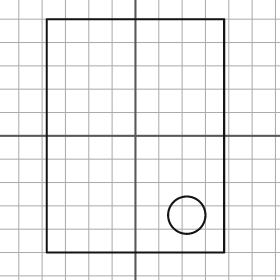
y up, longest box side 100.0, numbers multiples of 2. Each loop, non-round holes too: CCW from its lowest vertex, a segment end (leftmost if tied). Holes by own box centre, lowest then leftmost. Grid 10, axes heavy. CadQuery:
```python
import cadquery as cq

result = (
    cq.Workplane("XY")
    .moveTo(-38.0, -50.0)
    .lineTo(38.0, -50.0)
    .lineTo(38.0, 50.0)
    .lineTo(-38.0, 50.0)
    .close()
    .moveTo(22.0, -34.0)
    .circle(8.0)
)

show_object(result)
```